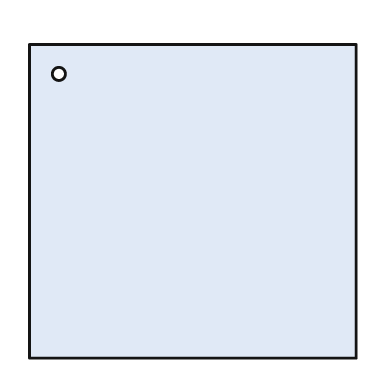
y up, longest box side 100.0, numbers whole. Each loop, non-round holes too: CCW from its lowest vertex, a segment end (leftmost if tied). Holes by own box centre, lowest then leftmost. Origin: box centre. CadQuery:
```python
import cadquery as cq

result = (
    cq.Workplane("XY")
    .moveTo(-50.0, -48.0)
    .lineTo(50.0, -48.0)
    .lineTo(50.0, 48.0)
    .lineTo(-50.0, 48.0)
    .close()
    .moveTo(-41.0, 39.0)
    .circle(2.0)
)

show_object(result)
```